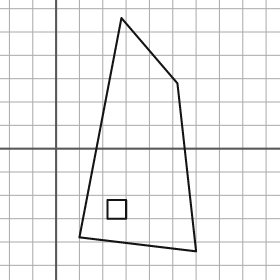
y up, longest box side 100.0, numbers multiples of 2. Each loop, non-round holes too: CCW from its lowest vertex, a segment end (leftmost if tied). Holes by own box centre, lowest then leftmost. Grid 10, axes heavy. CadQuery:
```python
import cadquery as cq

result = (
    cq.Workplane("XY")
    .moveTo(60.0, -44.0)
    .lineTo(52.0, 28.0)
    .lineTo(28.0, 56.0)
    .lineTo(10.0, -38.0)
    .close()
    .moveTo(22.0, -30.0)
    .lineTo(30.0, -30.0)
    .lineTo(30.0, -22.0)
    .lineTo(22.0, -22.0)
    .close()
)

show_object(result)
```